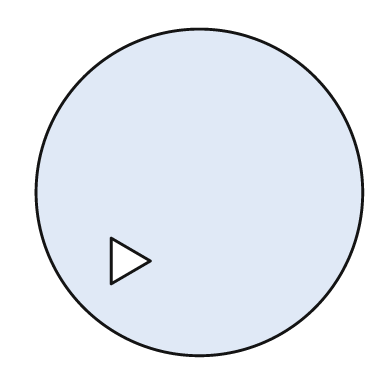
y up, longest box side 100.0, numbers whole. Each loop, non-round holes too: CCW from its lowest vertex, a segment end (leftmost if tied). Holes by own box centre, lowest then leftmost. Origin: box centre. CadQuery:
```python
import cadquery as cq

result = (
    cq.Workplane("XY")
    .moveTo(0.0, 0.0)
    .circle(50.0)
    .moveTo(-27.0, -28.0)
    .lineTo(-15.0, -21.0)
    .lineTo(-27.0, -14.0)
    .close()
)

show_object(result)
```